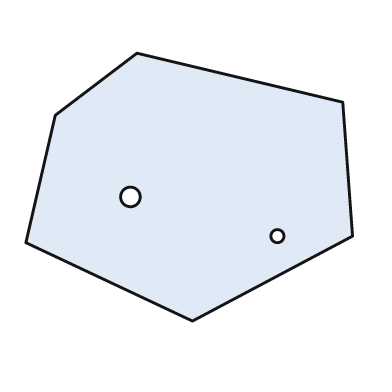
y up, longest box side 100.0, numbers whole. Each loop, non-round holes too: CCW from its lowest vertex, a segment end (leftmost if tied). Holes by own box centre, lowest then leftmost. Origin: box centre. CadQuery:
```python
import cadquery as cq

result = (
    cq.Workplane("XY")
    .moveTo(1.0, -41.0)
    .lineTo(50.0, -15.0)
    .lineTo(47.0, 26.0)
    .lineTo(-16.0, 41.0)
    .lineTo(-41.0, 22.0)
    .lineTo(-50.0, -17.0)
    .close()
    .moveTo(27.0, -15.0)
    .circle(2.0)
    .moveTo(-18.0, -3.0)
    .circle(3.0)
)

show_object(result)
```